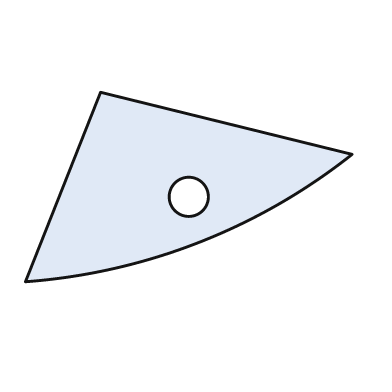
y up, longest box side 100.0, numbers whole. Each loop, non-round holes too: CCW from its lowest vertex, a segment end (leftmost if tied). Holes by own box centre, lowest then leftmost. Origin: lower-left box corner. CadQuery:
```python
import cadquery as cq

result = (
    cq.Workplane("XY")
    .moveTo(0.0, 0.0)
    .threePointArc((53.0, 12.0), (100.0, 39.0))
    .lineTo(23.0, 58.0)
    .close()
    .moveTo(50.0, 26.0)
    .circle(6.0)
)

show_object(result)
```